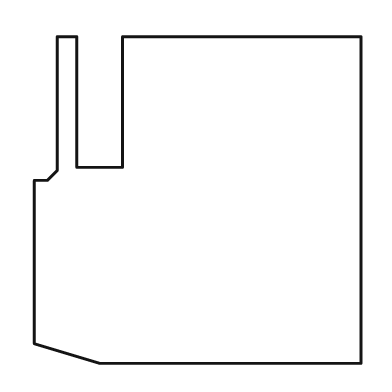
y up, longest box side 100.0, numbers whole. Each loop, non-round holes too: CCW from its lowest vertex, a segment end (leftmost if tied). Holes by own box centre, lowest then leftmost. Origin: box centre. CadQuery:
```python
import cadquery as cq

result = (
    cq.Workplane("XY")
    .moveTo(-30.0, -50.0)
    .lineTo(50.0, -50.0)
    .lineTo(50.0, 50.0)
    .lineTo(-23.0, 50.0)
    .lineTo(-23.0, 10.0)
    .lineTo(-37.0, 10.0)
    .lineTo(-37.0, 50.0)
    .lineTo(-43.0, 50.0)
    .lineTo(-43.0, 9.0)
    .lineTo(-46.0, 6.0)
    .lineTo(-50.0, 6.0)
    .lineTo(-50.0, -44.0)
    .close()
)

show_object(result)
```